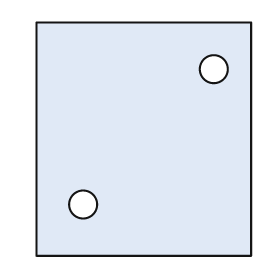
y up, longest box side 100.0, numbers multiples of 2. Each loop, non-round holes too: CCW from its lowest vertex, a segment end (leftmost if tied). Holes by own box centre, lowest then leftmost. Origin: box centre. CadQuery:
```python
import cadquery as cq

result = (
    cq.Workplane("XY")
    .moveTo(-46.0, -50.0)
    .lineTo(46.0, -50.0)
    .lineTo(46.0, 50.0)
    .lineTo(-46.0, 50.0)
    .close()
    .moveTo(-26.0, -28.0)
    .circle(6.0)
    .moveTo(30.0, 30.0)
    .circle(6.0)
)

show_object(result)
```